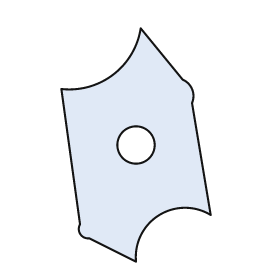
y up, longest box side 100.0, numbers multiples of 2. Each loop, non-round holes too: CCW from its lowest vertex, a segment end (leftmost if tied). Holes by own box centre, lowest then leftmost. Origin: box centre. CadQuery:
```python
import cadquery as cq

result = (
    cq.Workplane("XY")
    .moveTo(0.0, -50.0)
    .threePointArc((10.0, -30.0), (32.0, -30.0))
    .lineTo(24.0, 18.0)
    .threePointArc((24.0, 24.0), (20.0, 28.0))
    .lineTo(2.0, 50.0)
    .threePointArc((-10.0, 30.0), (-32.0, 24.0))
    .lineTo(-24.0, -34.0)
    .threePointArc((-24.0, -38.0), (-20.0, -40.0))
    .close()
    .moveTo(0.0, 0.0)
    .circle(8.0)
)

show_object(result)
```